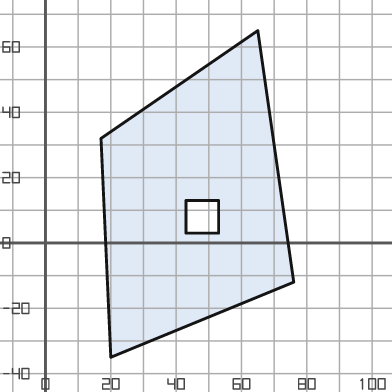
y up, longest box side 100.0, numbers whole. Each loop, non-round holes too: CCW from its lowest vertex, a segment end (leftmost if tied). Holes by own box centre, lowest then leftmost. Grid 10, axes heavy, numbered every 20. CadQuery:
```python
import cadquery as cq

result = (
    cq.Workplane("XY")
    .moveTo(20.0, -35.0)
    .lineTo(76.0, -12.0)
    .lineTo(65.0, 65.0)
    .lineTo(17.0, 32.0)
    .close()
    .moveTo(43.0, 3.0)
    .lineTo(53.0, 3.0)
    .lineTo(53.0, 13.0)
    .lineTo(43.0, 13.0)
    .close()
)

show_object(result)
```